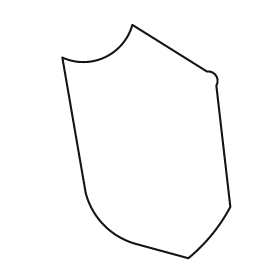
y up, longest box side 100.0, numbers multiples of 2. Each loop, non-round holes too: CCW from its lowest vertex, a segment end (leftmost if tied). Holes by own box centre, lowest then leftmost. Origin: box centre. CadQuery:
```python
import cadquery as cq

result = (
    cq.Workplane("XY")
    .moveTo(18.0, -50.0)
    .threePointArc((28.0, -40.0), (36.0, -28.0))
    .lineTo(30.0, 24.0)
    .threePointArc((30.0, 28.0), (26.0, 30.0))
    .lineTo(-6.0, 50.0)
    .threePointArc((-18.0, 36.0), (-36.0, 36.0))
    .lineTo(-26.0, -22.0)
    .threePointArc((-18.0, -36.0), (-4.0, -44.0))
    .close()
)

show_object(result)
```